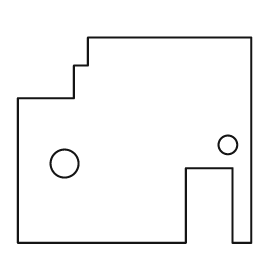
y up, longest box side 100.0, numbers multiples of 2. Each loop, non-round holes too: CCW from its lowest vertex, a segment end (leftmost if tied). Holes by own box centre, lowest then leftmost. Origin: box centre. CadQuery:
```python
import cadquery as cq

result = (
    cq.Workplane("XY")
    .moveTo(-50.0, -44.0)
    .lineTo(22.0, -44.0)
    .lineTo(22.0, -12.0)
    .lineTo(42.0, -12.0)
    .lineTo(42.0, -44.0)
    .lineTo(50.0, -44.0)
    .lineTo(50.0, 44.0)
    .lineTo(-20.0, 44.0)
    .lineTo(-20.0, 32.0)
    .lineTo(-26.0, 32.0)
    .lineTo(-26.0, 18.0)
    .lineTo(-50.0, 18.0)
    .close()
    .moveTo(-30.0, -10.0)
    .circle(6.0)
    .moveTo(40.0, -2.0)
    .circle(4.0)
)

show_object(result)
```